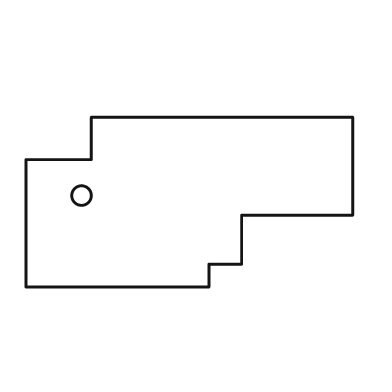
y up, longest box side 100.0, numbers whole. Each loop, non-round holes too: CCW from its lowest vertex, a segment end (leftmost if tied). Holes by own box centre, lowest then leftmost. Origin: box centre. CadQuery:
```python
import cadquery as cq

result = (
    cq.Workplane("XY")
    .moveTo(-50.0, -26.0)
    .lineTo(6.0, -26.0)
    .lineTo(6.0, -19.0)
    .lineTo(16.0, -19.0)
    .lineTo(16.0, -4.0)
    .lineTo(50.0, -4.0)
    .lineTo(50.0, 26.0)
    .lineTo(-30.0, 26.0)
    .lineTo(-30.0, 13.0)
    .lineTo(-50.0, 13.0)
    .close()
    .moveTo(-33.0, 2.0)
    .circle(3.0)
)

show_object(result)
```